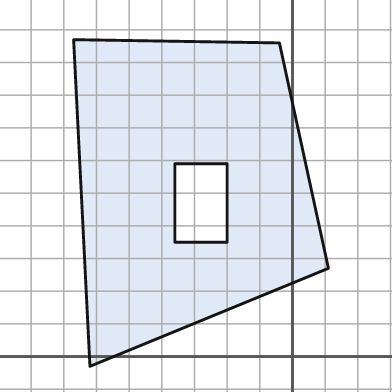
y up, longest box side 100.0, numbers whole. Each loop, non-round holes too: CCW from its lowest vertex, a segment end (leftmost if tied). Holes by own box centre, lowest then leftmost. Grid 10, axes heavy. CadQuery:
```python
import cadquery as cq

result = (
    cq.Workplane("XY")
    .moveTo(-62.0, -3.0)
    .lineTo(11.0, 27.0)
    .lineTo(-4.0, 96.0)
    .lineTo(-67.0, 97.0)
    .close()
    .moveTo(-36.0, 35.0)
    .lineTo(-20.0, 35.0)
    .lineTo(-20.0, 59.0)
    .lineTo(-36.0, 59.0)
    .close()
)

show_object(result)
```